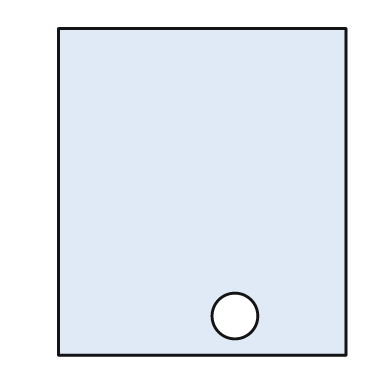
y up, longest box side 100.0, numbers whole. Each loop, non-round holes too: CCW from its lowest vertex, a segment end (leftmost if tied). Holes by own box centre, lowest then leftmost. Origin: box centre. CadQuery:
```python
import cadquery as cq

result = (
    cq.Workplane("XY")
    .moveTo(-44.0, -50.0)
    .lineTo(44.0, -50.0)
    .lineTo(44.0, 50.0)
    .lineTo(-44.0, 50.0)
    .close()
    .moveTo(10.0, -38.0)
    .circle(7.0)
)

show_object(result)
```